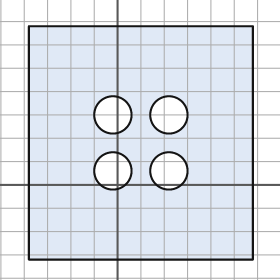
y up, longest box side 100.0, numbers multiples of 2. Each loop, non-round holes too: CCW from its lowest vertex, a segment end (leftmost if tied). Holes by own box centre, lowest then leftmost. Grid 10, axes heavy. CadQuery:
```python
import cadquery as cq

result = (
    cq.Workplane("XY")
    .moveTo(-38.0, -32.0)
    .lineTo(58.0, -32.0)
    .lineTo(58.0, 68.0)
    .lineTo(-38.0, 68.0)
    .close()
    .moveTo(-2.0, 6.0)
    .circle(8.0)
    .moveTo(22.0, 6.0)
    .circle(8.0)
    .moveTo(-2.0, 30.0)
    .circle(8.0)
    .moveTo(22.0, 30.0)
    .circle(8.0)
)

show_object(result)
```